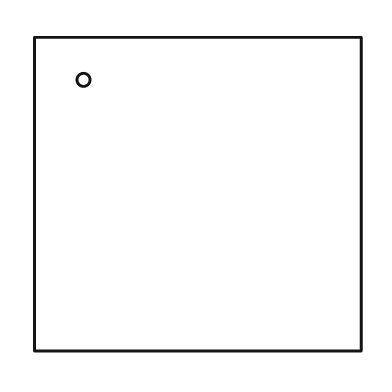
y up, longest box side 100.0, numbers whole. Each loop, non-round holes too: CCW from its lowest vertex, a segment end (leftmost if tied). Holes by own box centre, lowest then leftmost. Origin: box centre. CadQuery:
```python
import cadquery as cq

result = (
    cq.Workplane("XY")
    .moveTo(-50.0, -48.0)
    .lineTo(50.0, -48.0)
    .lineTo(50.0, 48.0)
    .lineTo(-50.0, 48.0)
    .close()
    .moveTo(-35.0, 35.0)
    .circle(2.0)
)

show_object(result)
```